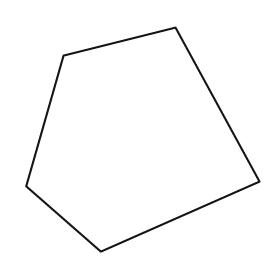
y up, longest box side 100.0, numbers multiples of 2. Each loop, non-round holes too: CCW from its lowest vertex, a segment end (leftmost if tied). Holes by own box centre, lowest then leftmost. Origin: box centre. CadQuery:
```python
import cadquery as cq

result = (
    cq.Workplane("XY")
    .moveTo(-18.0, -48.0)
    .lineTo(50.0, -18.0)
    .lineTo(14.0, 48.0)
    .lineTo(-34.0, 36.0)
    .lineTo(-50.0, -20.0)
    .close()
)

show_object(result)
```